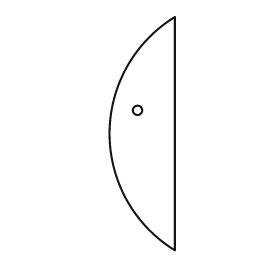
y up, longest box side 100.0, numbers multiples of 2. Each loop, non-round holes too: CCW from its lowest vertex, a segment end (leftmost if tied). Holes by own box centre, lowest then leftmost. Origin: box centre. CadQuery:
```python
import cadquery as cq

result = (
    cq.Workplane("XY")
    .moveTo(14.0, -50.0)
    .lineTo(14.0, 50.0)
    .threePointArc((-14.0, 0.0), (14.0, -50.0))
    .close()
    .moveTo(-2.0, 10.0)
    .circle(2.0)
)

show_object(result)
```